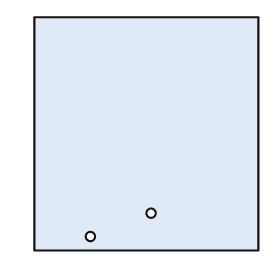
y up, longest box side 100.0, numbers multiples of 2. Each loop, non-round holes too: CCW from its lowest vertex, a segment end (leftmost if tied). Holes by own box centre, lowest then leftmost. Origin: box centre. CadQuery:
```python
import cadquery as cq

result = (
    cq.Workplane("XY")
    .moveTo(-48.0, -50.0)
    .lineTo(48.0, -50.0)
    .lineTo(48.0, 50.0)
    .lineTo(-48.0, 50.0)
    .close()
    .moveTo(-24.0, -44.0)
    .circle(2.0)
    .moveTo(2.0, -34.0)
    .circle(2.0)
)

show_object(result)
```